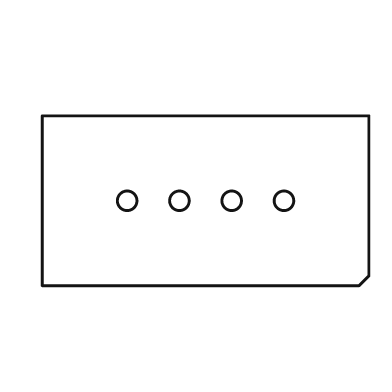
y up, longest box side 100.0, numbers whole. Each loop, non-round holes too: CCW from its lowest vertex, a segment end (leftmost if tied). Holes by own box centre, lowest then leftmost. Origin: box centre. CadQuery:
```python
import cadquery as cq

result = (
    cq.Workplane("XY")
    .moveTo(-50.0, -26.0)
    .lineTo(47.0, -26.0)
    .lineTo(50.0, -23.0)
    .lineTo(50.0, 26.0)
    .lineTo(-50.0, 26.0)
    .close()
    .moveTo(-24.0, 0.0)
    .circle(3.0)
    .moveTo(-8.0, 0.0)
    .circle(3.0)
    .moveTo(8.0, 0.0)
    .circle(3.0)
    .moveTo(24.0, 0.0)
    .circle(3.0)
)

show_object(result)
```